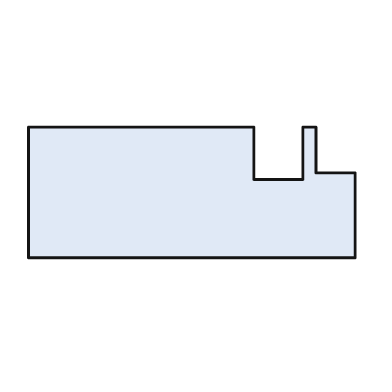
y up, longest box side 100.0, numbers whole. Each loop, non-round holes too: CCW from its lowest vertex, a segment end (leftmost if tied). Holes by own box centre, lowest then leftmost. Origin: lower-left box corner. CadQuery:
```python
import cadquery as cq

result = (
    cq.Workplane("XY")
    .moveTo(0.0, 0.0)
    .lineTo(100.0, 0.0)
    .lineTo(100.0, 26.0)
    .lineTo(88.0, 26.0)
    .lineTo(88.0, 40.0)
    .lineTo(84.0, 40.0)
    .lineTo(84.0, 24.0)
    .lineTo(69.0, 24.0)
    .lineTo(69.0, 40.0)
    .lineTo(0.0, 40.0)
    .close()
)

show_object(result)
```